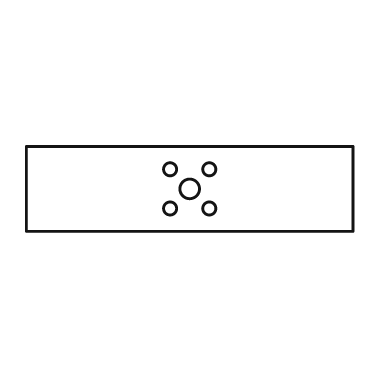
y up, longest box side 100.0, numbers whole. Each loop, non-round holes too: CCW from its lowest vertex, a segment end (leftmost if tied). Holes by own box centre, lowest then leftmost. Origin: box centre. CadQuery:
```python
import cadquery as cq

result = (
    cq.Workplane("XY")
    .moveTo(-50.0, -13.0)
    .lineTo(50.0, -13.0)
    .lineTo(50.0, 13.0)
    .lineTo(-50.0, 13.0)
    .close()
    .moveTo(-6.0, -6.0)
    .circle(2.0)
    .moveTo(6.0, -6.0)
    .circle(2.0)
    .moveTo(0.0, 0.0)
    .circle(3.0)
    .moveTo(-6.0, 6.0)
    .circle(2.0)
    .moveTo(6.0, 6.0)
    .circle(2.0)
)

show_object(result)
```